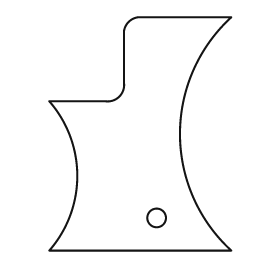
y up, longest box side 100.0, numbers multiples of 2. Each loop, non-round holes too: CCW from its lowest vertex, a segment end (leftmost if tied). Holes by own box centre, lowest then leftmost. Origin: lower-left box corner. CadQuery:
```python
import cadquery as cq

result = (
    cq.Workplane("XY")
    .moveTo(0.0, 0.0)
    .lineTo(78.0, 0.0)
    .threePointArc((56.0, 50.0), (78.0, 100.0))
    .lineTo(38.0, 100.0)
    .threePointArc((34.0, 98.0), (32.0, 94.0))
    .lineTo(32.0, 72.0)
    .threePointArc((30.0, 66.0), (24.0, 64.0))
    .lineTo(0.0, 64.0)
    .threePointArc((12.0, 32.0), (0.0, 0.0))
    .close()
    .moveTo(46.0, 14.0)
    .circle(4.0)
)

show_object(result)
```